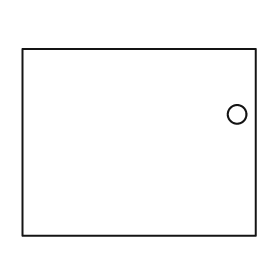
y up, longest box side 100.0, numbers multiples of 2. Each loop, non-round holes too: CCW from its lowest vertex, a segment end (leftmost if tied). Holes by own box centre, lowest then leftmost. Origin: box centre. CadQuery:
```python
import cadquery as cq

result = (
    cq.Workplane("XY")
    .moveTo(-50.0, -40.0)
    .lineTo(50.0, -40.0)
    .lineTo(50.0, 40.0)
    .lineTo(-50.0, 40.0)
    .close()
    .moveTo(42.0, 12.0)
    .circle(4.0)
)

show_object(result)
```